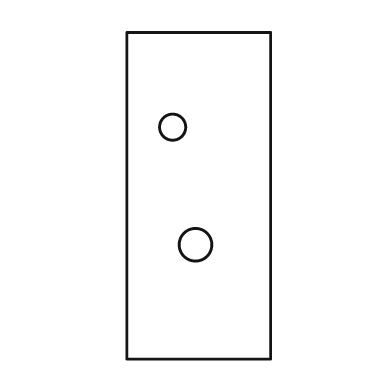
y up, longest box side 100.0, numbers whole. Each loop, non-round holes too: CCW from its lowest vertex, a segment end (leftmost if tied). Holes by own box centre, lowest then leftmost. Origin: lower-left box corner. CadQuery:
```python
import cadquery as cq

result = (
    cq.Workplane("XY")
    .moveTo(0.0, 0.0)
    .lineTo(44.0, 0.0)
    .lineTo(44.0, 100.0)
    .lineTo(0.0, 100.0)
    .close()
    .moveTo(21.0, 35.0)
    .circle(5.0)
    .moveTo(14.0, 71.0)
    .circle(4.0)
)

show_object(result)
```